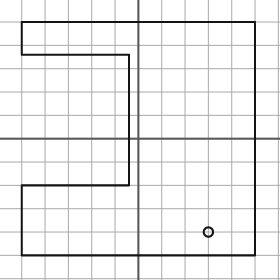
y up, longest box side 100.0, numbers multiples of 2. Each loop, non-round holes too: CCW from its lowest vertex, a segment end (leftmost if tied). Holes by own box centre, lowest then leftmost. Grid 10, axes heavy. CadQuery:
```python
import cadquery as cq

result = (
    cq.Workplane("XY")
    .moveTo(-50.0, -50.0)
    .lineTo(50.0, -50.0)
    .lineTo(50.0, 50.0)
    .lineTo(-50.0, 50.0)
    .lineTo(-50.0, 36.0)
    .lineTo(-4.0, 36.0)
    .lineTo(-4.0, -20.0)
    .lineTo(-50.0, -20.0)
    .close()
    .moveTo(30.0, -40.0)
    .circle(2.0)
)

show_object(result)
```